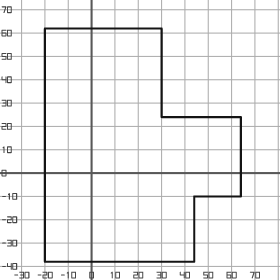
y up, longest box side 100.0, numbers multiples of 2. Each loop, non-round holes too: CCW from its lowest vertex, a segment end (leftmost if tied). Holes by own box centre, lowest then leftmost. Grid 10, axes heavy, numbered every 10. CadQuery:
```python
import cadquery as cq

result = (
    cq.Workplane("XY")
    .moveTo(-20.0, -38.0)
    .lineTo(44.0, -38.0)
    .lineTo(44.0, -10.0)
    .lineTo(64.0, -10.0)
    .lineTo(64.0, 24.0)
    .lineTo(30.0, 24.0)
    .lineTo(30.0, 62.0)
    .lineTo(-20.0, 62.0)
    .close()
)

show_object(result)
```